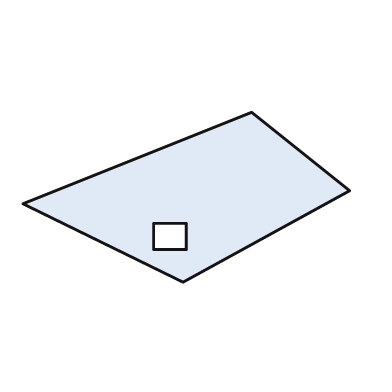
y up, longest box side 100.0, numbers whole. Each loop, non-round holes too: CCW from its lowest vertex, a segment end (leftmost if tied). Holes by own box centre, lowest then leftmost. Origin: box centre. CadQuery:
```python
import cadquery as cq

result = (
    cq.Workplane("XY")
    .moveTo(-1.0, -26.0)
    .lineTo(50.0, 2.0)
    .lineTo(20.0, 26.0)
    .lineTo(-50.0, -2.0)
    .close()
    .moveTo(-10.0, -16.0)
    .lineTo(0.0, -16.0)
    .lineTo(0.0, -8.0)
    .lineTo(-10.0, -8.0)
    .close()
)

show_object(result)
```